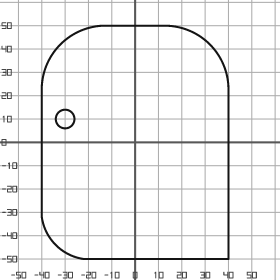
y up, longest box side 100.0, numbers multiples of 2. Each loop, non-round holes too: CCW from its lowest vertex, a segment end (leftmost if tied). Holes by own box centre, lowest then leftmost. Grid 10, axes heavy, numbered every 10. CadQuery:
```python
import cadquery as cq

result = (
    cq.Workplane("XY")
    .moveTo(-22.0, -50.0)
    .lineTo(40.0, -50.0)
    .lineTo(40.0, 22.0)
    .threePointArc((32.0, 42.0), (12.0, 50.0))
    .lineTo(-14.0, 50.0)
    .threePointArc((-32.0, 42.0), (-40.0, 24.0))
    .lineTo(-40.0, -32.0)
    .threePointArc((-34.0, -44.0), (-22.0, -50.0))
    .close()
    .moveTo(-30.0, 10.0)
    .circle(4.0)
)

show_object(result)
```